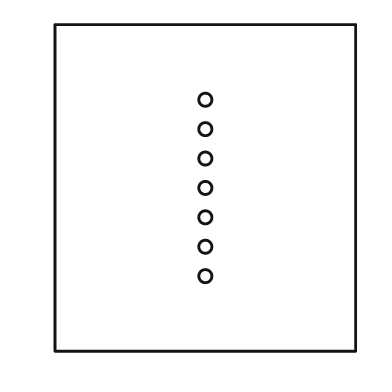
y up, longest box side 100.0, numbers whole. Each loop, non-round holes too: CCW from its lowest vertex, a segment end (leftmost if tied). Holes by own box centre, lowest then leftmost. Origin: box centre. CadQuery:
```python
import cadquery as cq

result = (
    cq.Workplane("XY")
    .moveTo(-46.0, -50.0)
    .lineTo(46.0, -50.0)
    .lineTo(46.0, 50.0)
    .lineTo(-46.0, 50.0)
    .close()
    .moveTo(0.0, -27.0)
    .circle(2.0)
    .moveTo(0.0, -18.0)
    .circle(2.0)
    .moveTo(0.0, -9.0)
    .circle(2.0)
    .moveTo(0.0, 0.0)
    .circle(2.0)
    .moveTo(0.0, 9.0)
    .circle(2.0)
    .moveTo(0.0, 18.0)
    .circle(2.0)
    .moveTo(0.0, 27.0)
    .circle(2.0)
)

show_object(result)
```